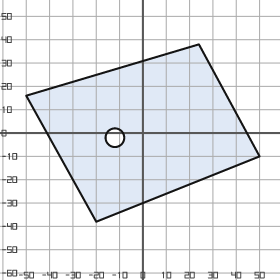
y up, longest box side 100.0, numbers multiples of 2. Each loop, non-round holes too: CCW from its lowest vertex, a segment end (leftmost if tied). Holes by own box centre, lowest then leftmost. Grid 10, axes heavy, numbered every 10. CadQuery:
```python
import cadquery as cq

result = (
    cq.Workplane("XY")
    .moveTo(-20.0, -38.0)
    .lineTo(50.0, -10.0)
    .lineTo(24.0, 38.0)
    .lineTo(-50.0, 16.0)
    .close()
    .moveTo(-12.0, -2.0)
    .circle(4.0)
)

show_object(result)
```